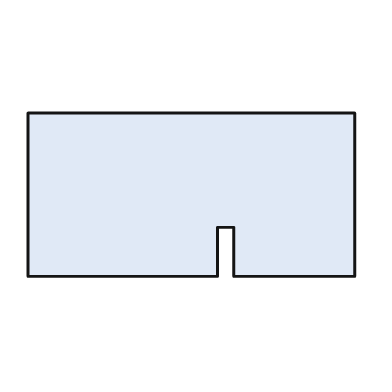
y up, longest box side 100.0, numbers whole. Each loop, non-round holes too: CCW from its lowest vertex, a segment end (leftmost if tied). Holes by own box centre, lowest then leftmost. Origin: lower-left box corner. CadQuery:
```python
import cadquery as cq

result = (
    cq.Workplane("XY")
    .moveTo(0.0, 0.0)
    .lineTo(58.0, 0.0)
    .lineTo(58.0, 15.0)
    .lineTo(63.0, 15.0)
    .lineTo(63.0, 0.0)
    .lineTo(100.0, 0.0)
    .lineTo(100.0, 50.0)
    .lineTo(0.0, 50.0)
    .close()
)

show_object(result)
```